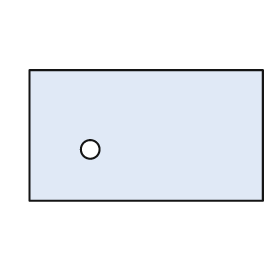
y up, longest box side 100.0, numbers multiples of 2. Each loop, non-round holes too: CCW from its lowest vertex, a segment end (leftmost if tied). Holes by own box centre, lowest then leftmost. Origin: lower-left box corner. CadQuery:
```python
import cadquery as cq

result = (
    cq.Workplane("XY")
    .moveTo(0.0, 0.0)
    .lineTo(100.0, 0.0)
    .lineTo(100.0, 56.0)
    .lineTo(0.0, 56.0)
    .close()
    .moveTo(26.0, 22.0)
    .circle(4.0)
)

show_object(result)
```